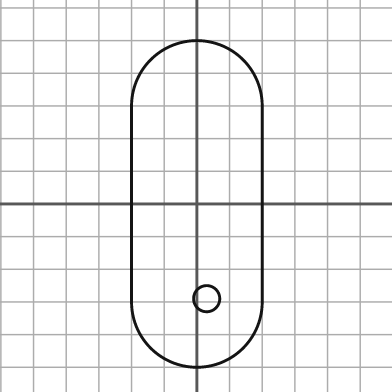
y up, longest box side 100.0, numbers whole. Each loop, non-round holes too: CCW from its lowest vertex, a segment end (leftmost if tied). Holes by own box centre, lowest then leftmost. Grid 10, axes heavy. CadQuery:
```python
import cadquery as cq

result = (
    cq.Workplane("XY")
    .moveTo(-20.0, -30.0)
    .threePointArc((0.0, -50.0), (20.0, -30.0))
    .lineTo(20.0, 30.0)
    .threePointArc((0.0, 50.0), (-20.0, 30.0))
    .close()
    .moveTo(3.0, -29.0)
    .circle(4.0)
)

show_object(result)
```